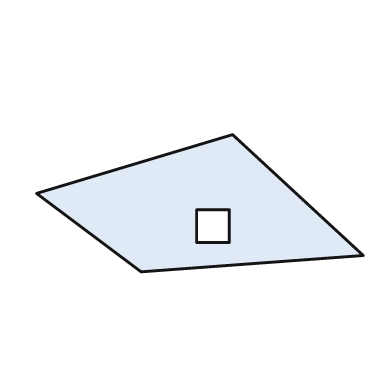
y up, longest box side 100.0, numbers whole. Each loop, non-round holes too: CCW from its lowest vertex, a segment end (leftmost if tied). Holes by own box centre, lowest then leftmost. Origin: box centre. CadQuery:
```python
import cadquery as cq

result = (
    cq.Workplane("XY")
    .moveTo(-18.0, -21.0)
    .lineTo(50.0, -16.0)
    .lineTo(10.0, 21.0)
    .lineTo(-50.0, 3.0)
    .close()
    .moveTo(-1.0, -12.0)
    .lineTo(9.0, -12.0)
    .lineTo(9.0, -2.0)
    .lineTo(-1.0, -2.0)
    .close()
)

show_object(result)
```